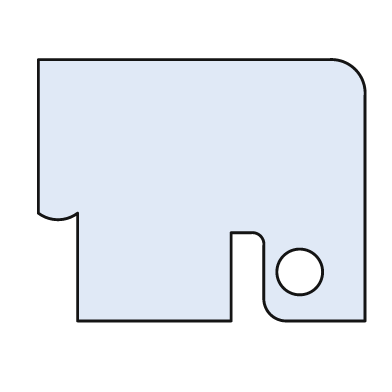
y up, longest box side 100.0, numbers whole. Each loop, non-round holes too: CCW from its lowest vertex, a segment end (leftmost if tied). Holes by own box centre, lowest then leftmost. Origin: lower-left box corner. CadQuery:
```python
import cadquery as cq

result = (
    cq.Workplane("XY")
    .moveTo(12.0, 0.0)
    .lineTo(59.0, 0.0)
    .lineTo(59.0, 27.0)
    .lineTo(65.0, 27.0)
    .threePointArc((68.0, 26.0), (69.0, 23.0))
    .lineTo(69.0, 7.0)
    .threePointArc((71.0, 2.0), (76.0, 0.0))
    .lineTo(100.0, 0.0)
    .lineTo(100.0, 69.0)
    .threePointArc((97.0, 77.0), (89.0, 80.0))
    .lineTo(0.0, 80.0)
    .lineTo(0.0, 33.0)
    .threePointArc((6.0, 31.0), (12.0, 33.0))
    .close()
    .moveTo(80.0, 15.0)
    .circle(7.0)
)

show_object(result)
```